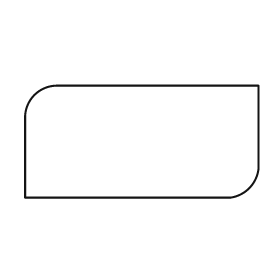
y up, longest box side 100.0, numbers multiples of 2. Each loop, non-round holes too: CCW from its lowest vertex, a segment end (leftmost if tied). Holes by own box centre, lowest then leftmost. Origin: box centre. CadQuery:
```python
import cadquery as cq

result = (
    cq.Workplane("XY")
    .moveTo(-50.0, -24.0)
    .lineTo(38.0, -24.0)
    .threePointArc((46.0, -20.0), (50.0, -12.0))
    .lineTo(50.0, 24.0)
    .lineTo(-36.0, 24.0)
    .threePointArc((-46.0, 20.0), (-50.0, 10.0))
    .close()
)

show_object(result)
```